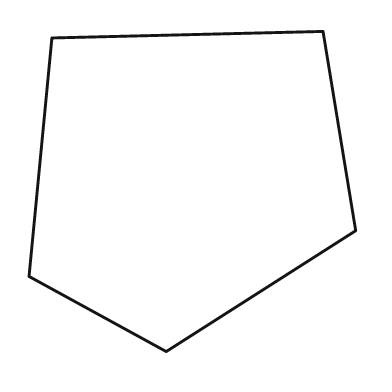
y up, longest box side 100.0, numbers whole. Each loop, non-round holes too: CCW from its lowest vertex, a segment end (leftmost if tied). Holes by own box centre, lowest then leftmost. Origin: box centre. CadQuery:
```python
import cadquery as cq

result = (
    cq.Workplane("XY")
    .moveTo(-8.0, -49.0)
    .lineTo(50.0, -12.0)
    .lineTo(40.0, 49.0)
    .lineTo(-43.0, 47.0)
    .lineTo(-50.0, -26.0)
    .close()
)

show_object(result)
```